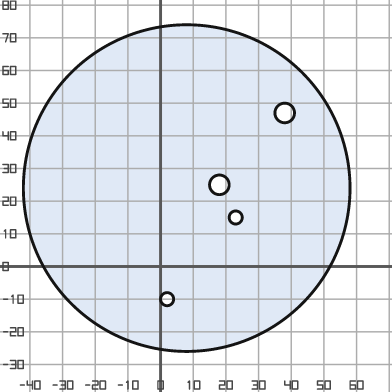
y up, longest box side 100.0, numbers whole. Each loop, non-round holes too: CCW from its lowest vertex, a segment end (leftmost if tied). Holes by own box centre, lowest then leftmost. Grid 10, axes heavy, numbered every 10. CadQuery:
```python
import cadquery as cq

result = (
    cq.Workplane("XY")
    .moveTo(8.0, 24.0)
    .circle(50.0)
    .moveTo(2.0, -10.0)
    .circle(2.0)
    .moveTo(23.0, 15.0)
    .circle(2.0)
    .moveTo(18.0, 25.0)
    .circle(3.0)
    .moveTo(38.0, 47.0)
    .circle(3.0)
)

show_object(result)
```